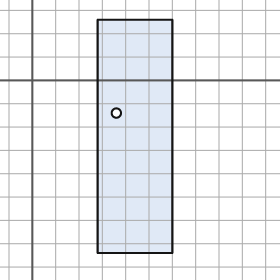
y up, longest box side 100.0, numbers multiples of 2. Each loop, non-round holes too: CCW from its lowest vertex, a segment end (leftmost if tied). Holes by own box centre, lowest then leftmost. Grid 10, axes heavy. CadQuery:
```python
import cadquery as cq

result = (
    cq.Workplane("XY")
    .moveTo(28.0, -74.0)
    .lineTo(60.0, -74.0)
    .lineTo(60.0, 26.0)
    .lineTo(28.0, 26.0)
    .close()
    .moveTo(36.0, -14.0)
    .circle(2.0)
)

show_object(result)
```